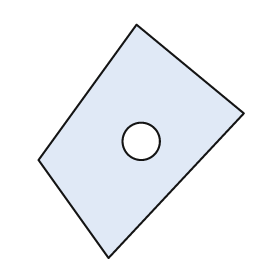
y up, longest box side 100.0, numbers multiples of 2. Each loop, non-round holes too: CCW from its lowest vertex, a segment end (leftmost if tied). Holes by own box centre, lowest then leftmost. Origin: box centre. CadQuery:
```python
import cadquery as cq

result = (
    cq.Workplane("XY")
    .moveTo(-14.0, -50.0)
    .lineTo(44.0, 12.0)
    .lineTo(-2.0, 50.0)
    .lineTo(-44.0, -8.0)
    .close()
    .moveTo(0.0, 0.0)
    .circle(8.0)
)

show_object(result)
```